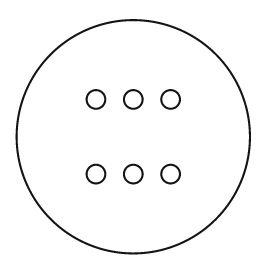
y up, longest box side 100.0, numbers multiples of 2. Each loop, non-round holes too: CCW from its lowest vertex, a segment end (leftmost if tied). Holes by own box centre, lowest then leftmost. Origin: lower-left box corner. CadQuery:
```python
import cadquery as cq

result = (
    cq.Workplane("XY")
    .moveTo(50.0, 50.0)
    .circle(50.0)
    .moveTo(34.0, 34.0)
    .circle(4.0)
    .moveTo(50.0, 34.0)
    .circle(4.0)
    .moveTo(66.0, 34.0)
    .circle(4.0)
    .moveTo(34.0, 66.0)
    .circle(4.0)
    .moveTo(50.0, 66.0)
    .circle(4.0)
    .moveTo(66.0, 66.0)
    .circle(4.0)
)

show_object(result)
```